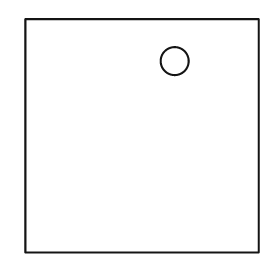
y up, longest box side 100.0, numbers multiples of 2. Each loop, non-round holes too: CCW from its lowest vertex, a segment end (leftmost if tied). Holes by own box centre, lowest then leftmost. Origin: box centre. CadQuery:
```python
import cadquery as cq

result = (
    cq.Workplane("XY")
    .moveTo(-50.0, -50.0)
    .lineTo(50.0, -50.0)
    .lineTo(50.0, 50.0)
    .lineTo(-50.0, 50.0)
    .close()
    .moveTo(14.0, 32.0)
    .circle(6.0)
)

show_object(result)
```